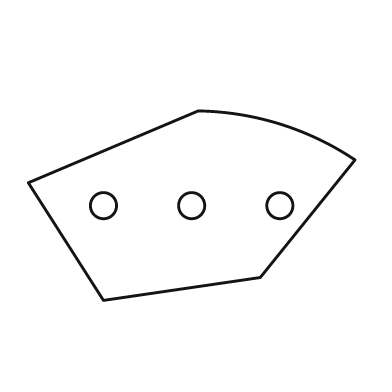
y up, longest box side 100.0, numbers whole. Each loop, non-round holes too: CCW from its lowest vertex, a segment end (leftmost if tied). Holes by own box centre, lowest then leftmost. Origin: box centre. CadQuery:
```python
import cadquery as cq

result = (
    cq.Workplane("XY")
    .moveTo(-27.0, -29.0)
    .lineTo(21.0, -22.0)
    .lineTo(50.0, 14.0)
    .threePointArc((27.0, 25.0), (2.0, 29.0))
    .lineTo(-50.0, 7.0)
    .close()
    .moveTo(-27.0, 0.0)
    .circle(4.0)
    .moveTo(0.0, 0.0)
    .circle(4.0)
    .moveTo(27.0, 0.0)
    .circle(4.0)
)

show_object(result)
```